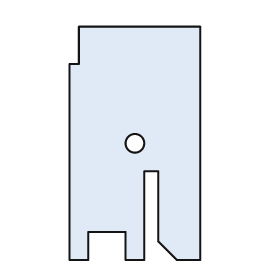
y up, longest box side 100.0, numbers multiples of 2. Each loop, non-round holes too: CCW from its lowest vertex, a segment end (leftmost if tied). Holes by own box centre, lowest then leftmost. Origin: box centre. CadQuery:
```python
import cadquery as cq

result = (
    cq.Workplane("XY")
    .moveTo(-28.0, -50.0)
    .lineTo(-20.0, -50.0)
    .lineTo(-20.0, -38.0)
    .lineTo(-4.0, -38.0)
    .lineTo(-4.0, -50.0)
    .lineTo(4.0, -50.0)
    .lineTo(4.0, -12.0)
    .lineTo(10.0, -12.0)
    .lineTo(10.0, -42.0)
    .lineTo(18.0, -50.0)
    .lineTo(28.0, -50.0)
    .lineTo(28.0, 50.0)
    .lineTo(-24.0, 50.0)
    .lineTo(-24.0, 34.0)
    .lineTo(-28.0, 34.0)
    .close()
    .moveTo(0.0, 0.0)
    .circle(4.0)
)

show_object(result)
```